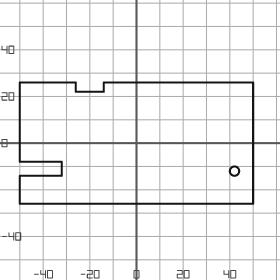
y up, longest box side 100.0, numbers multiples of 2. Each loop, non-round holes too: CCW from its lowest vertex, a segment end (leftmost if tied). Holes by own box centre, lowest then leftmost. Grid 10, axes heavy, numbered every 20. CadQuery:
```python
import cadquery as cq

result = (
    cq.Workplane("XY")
    .moveTo(-50.0, -26.0)
    .lineTo(50.0, -26.0)
    .lineTo(50.0, 26.0)
    .lineTo(-14.0, 26.0)
    .lineTo(-14.0, 22.0)
    .lineTo(-26.0, 22.0)
    .lineTo(-26.0, 26.0)
    .lineTo(-50.0, 26.0)
    .lineTo(-50.0, -8.0)
    .lineTo(-32.0, -8.0)
    .lineTo(-32.0, -14.0)
    .lineTo(-50.0, -14.0)
    .close()
    .moveTo(42.0, -12.0)
    .circle(2.0)
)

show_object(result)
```